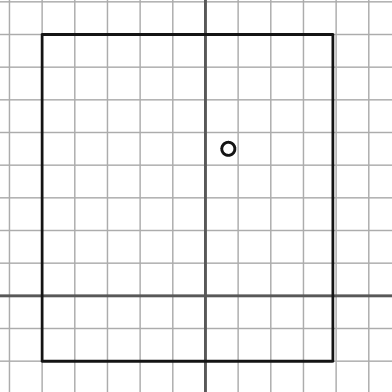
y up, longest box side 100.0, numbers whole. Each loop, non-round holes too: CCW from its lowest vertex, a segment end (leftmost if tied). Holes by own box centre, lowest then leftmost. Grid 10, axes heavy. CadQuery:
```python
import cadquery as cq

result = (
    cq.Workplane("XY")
    .moveTo(-50.0, -20.0)
    .lineTo(39.0, -20.0)
    .lineTo(39.0, 80.0)
    .lineTo(-50.0, 80.0)
    .close()
    .moveTo(7.0, 45.0)
    .circle(2.0)
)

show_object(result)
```